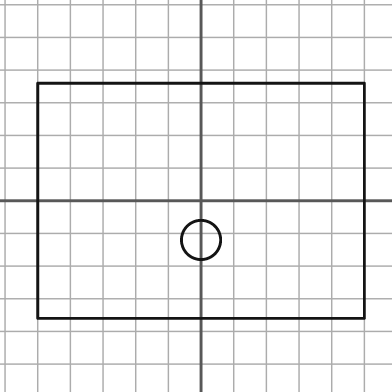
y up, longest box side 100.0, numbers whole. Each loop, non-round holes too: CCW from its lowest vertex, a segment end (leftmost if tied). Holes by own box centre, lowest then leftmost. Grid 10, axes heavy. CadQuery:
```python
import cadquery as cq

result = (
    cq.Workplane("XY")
    .moveTo(-50.0, -36.0)
    .lineTo(50.0, -36.0)
    .lineTo(50.0, 36.0)
    .lineTo(-50.0, 36.0)
    .close()
    .moveTo(0.0, -12.0)
    .circle(6.0)
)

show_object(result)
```